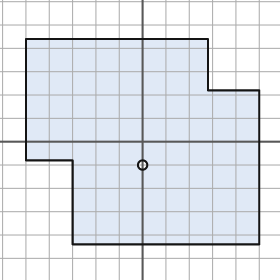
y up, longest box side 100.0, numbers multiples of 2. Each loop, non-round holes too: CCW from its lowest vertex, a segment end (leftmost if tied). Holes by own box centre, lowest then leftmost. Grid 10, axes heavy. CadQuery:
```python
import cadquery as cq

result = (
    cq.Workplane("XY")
    .moveTo(-30.0, -44.0)
    .lineTo(50.0, -44.0)
    .lineTo(50.0, 22.0)
    .lineTo(28.0, 22.0)
    .lineTo(28.0, 44.0)
    .lineTo(-50.0, 44.0)
    .lineTo(-50.0, -8.0)
    .lineTo(-30.0, -8.0)
    .close()
    .moveTo(0.0, -10.0)
    .circle(2.0)
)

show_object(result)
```